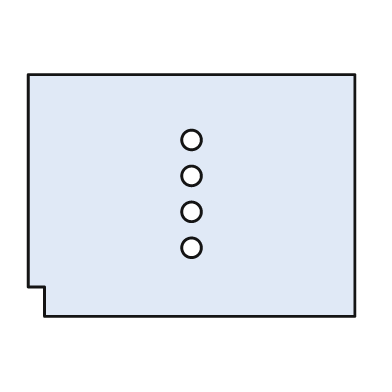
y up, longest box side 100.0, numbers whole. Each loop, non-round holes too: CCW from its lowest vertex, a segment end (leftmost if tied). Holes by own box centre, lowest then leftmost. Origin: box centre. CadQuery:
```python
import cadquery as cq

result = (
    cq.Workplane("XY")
    .moveTo(-45.0, -37.0)
    .lineTo(50.0, -37.0)
    .lineTo(50.0, 37.0)
    .lineTo(-50.0, 37.0)
    .lineTo(-50.0, -28.0)
    .lineTo(-45.0, -28.0)
    .close()
    .moveTo(0.0, -16.0)
    .circle(3.0)
    .moveTo(0.0, -5.0)
    .circle(3.0)
    .moveTo(0.0, 6.0)
    .circle(3.0)
    .moveTo(0.0, 17.0)
    .circle(3.0)
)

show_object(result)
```